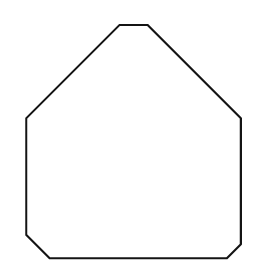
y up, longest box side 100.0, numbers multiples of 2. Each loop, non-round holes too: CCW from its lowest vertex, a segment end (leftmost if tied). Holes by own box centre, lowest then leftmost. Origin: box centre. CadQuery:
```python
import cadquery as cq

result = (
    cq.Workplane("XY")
    .moveTo(-36.0, -50.0)
    .lineTo(40.0, -50.0)
    .lineTo(46.0, -44.0)
    .lineTo(46.0, 10.0)
    .lineTo(6.0, 50.0)
    .lineTo(-6.0, 50.0)
    .lineTo(-46.0, 10.0)
    .lineTo(-46.0, -40.0)
    .close()
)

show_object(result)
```